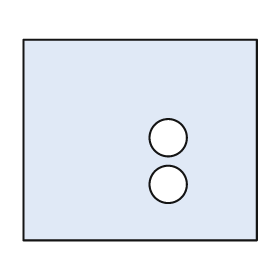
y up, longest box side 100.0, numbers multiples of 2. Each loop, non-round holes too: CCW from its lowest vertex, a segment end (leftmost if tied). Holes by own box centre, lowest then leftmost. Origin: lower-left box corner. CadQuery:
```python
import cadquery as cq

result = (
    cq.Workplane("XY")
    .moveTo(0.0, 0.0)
    .lineTo(100.0, 0.0)
    .lineTo(100.0, 86.0)
    .lineTo(0.0, 86.0)
    .close()
    .moveTo(62.0, 24.0)
    .circle(8.0)
    .moveTo(62.0, 44.0)
    .circle(8.0)
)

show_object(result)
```